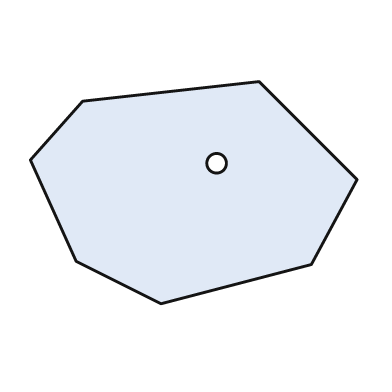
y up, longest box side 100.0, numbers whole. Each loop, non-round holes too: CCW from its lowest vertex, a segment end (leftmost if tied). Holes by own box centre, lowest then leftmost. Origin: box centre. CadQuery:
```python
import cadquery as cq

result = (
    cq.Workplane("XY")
    .moveTo(-10.0, -34.0)
    .lineTo(36.0, -22.0)
    .lineTo(50.0, 4.0)
    .lineTo(20.0, 34.0)
    .lineTo(-34.0, 28.0)
    .lineTo(-50.0, 10.0)
    .lineTo(-36.0, -21.0)
    .close()
    .moveTo(7.0, 9.0)
    .circle(3.0)
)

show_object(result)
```